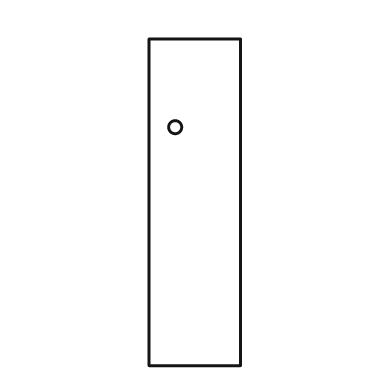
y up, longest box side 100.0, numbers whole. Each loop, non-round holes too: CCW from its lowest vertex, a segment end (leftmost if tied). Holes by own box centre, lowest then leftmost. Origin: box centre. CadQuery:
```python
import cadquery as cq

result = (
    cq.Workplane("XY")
    .moveTo(-14.0, -50.0)
    .lineTo(14.0, -50.0)
    .lineTo(14.0, 50.0)
    .lineTo(-14.0, 50.0)
    .close()
    .moveTo(-6.0, 23.0)
    .circle(2.0)
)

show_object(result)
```